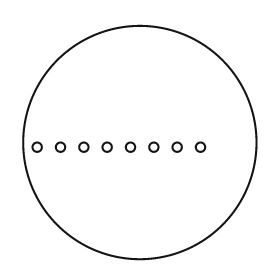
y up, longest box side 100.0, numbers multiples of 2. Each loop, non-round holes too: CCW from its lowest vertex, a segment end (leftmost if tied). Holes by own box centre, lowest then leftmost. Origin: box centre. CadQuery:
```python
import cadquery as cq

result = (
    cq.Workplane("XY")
    .moveTo(0.0, 0.0)
    .circle(50.0)
    .moveTo(-44.0, -2.0)
    .circle(2.0)
    .moveTo(-34.0, -2.0)
    .circle(2.0)
    .moveTo(-24.0, -2.0)
    .circle(2.0)
    .moveTo(-14.0, -2.0)
    .circle(2.0)
    .moveTo(-4.0, -2.0)
    .circle(2.0)
    .moveTo(6.0, -2.0)
    .circle(2.0)
    .moveTo(16.0, -2.0)
    .circle(2.0)
    .moveTo(26.0, -2.0)
    .circle(2.0)
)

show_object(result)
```